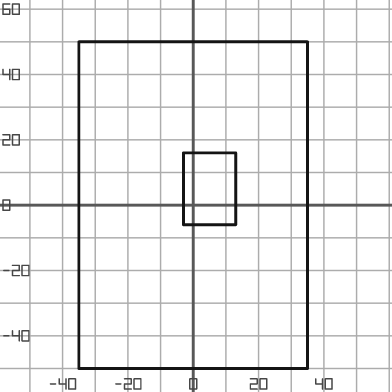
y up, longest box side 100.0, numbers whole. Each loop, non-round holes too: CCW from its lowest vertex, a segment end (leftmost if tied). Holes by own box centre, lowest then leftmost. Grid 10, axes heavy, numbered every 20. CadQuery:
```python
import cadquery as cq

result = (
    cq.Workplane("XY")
    .moveTo(-35.0, -50.0)
    .lineTo(35.0, -50.0)
    .lineTo(35.0, 50.0)
    .lineTo(-35.0, 50.0)
    .close()
    .moveTo(-3.0, -6.0)
    .lineTo(13.0, -6.0)
    .lineTo(13.0, 16.0)
    .lineTo(-3.0, 16.0)
    .close()
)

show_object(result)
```